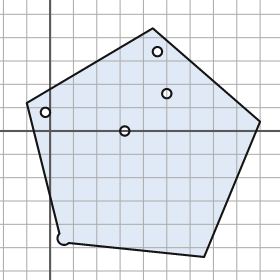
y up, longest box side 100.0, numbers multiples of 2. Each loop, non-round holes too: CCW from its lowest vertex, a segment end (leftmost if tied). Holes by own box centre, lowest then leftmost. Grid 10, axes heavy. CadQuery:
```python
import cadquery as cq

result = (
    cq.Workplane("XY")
    .moveTo(66.0, -54.0)
    .lineTo(90.0, 4.0)
    .lineTo(44.0, 44.0)
    .lineTo(-10.0, 12.0)
    .lineTo(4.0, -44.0)
    .threePointArc((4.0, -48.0), (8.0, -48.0))
    .close()
    .moveTo(32.0, 0.0)
    .circle(2.0)
    .moveTo(-2.0, 8.0)
    .circle(2.0)
    .moveTo(50.0, 16.0)
    .circle(2.0)
    .moveTo(46.0, 34.0)
    .circle(2.0)
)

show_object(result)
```